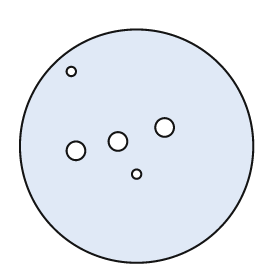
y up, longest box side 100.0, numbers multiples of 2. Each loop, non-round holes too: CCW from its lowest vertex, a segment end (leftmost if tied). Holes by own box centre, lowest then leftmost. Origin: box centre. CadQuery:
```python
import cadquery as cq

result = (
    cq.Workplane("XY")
    .moveTo(0.0, 0.0)
    .circle(50.0)
    .moveTo(0.0, -12.0)
    .circle(2.0)
    .moveTo(-26.0, -2.0)
    .circle(4.0)
    .moveTo(-8.0, 2.0)
    .circle(4.0)
    .moveTo(12.0, 8.0)
    .circle(4.0)
    .moveTo(-28.0, 32.0)
    .circle(2.0)
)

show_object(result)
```